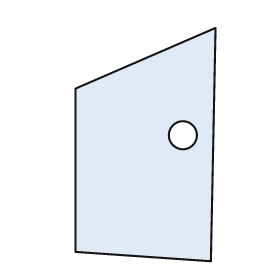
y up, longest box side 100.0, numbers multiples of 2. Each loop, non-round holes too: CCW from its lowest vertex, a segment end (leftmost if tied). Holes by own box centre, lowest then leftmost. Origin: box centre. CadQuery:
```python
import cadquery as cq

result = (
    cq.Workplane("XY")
    .moveTo(28.0, -50.0)
    .lineTo(30.0, 50.0)
    .lineTo(-30.0, 24.0)
    .lineTo(-30.0, -46.0)
    .close()
    .moveTo(16.0, 4.0)
    .circle(6.0)
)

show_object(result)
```